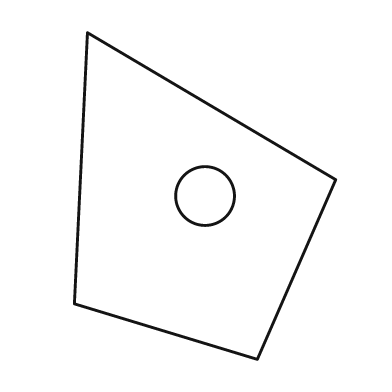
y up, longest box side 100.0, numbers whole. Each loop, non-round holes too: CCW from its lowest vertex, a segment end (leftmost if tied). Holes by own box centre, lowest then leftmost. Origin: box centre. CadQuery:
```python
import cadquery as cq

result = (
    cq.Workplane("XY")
    .moveTo(16.0, -50.0)
    .lineTo(40.0, 5.0)
    .lineTo(-36.0, 50.0)
    .lineTo(-40.0, -33.0)
    .close()
    .moveTo(0.0, 0.0)
    .circle(9.0)
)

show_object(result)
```